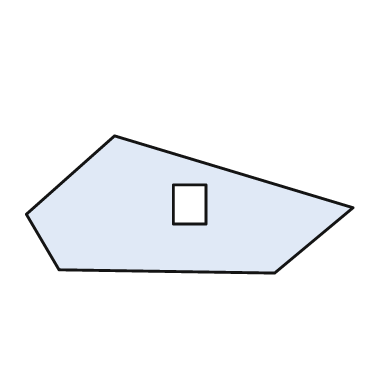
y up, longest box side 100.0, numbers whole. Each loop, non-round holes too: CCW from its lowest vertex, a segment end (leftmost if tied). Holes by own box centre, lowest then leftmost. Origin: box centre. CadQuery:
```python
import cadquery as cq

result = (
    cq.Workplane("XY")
    .moveTo(26.0, -21.0)
    .lineTo(50.0, -1.0)
    .lineTo(-23.0, 21.0)
    .lineTo(-50.0, -3.0)
    .lineTo(-40.0, -20.0)
    .close()
    .moveTo(-5.0, -6.0)
    .lineTo(5.0, -6.0)
    .lineTo(5.0, 6.0)
    .lineTo(-5.0, 6.0)
    .close()
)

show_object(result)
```